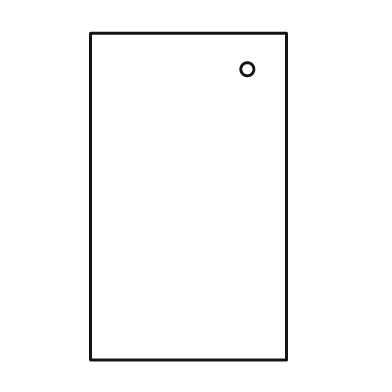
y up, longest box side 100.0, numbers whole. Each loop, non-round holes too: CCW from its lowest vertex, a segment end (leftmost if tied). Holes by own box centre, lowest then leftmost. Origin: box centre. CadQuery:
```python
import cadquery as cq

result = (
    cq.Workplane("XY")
    .moveTo(-30.0, -50.0)
    .lineTo(30.0, -50.0)
    .lineTo(30.0, 50.0)
    .lineTo(-30.0, 50.0)
    .close()
    .moveTo(18.0, 39.0)
    .circle(2.0)
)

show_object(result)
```